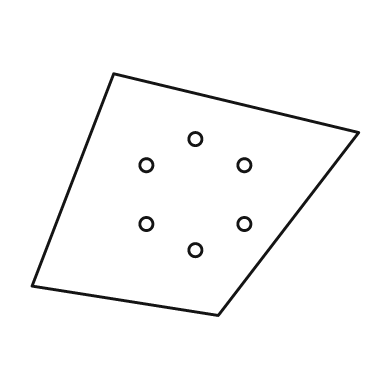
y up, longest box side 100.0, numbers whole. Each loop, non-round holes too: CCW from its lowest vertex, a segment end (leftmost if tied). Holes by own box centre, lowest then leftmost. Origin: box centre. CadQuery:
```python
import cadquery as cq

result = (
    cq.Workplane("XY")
    .moveTo(7.0, -37.0)
    .lineTo(50.0, 19.0)
    .lineTo(-25.0, 37.0)
    .lineTo(-50.0, -28.0)
    .close()
    .moveTo(0.0, -17.0)
    .circle(2.0)
    .moveTo(-15.0, -9.0)
    .circle(2.0)
    .moveTo(15.0, -9.0)
    .circle(2.0)
    .moveTo(-15.0, 9.0)
    .circle(2.0)
    .moveTo(15.0, 9.0)
    .circle(2.0)
    .moveTo(0.0, 17.0)
    .circle(2.0)
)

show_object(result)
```